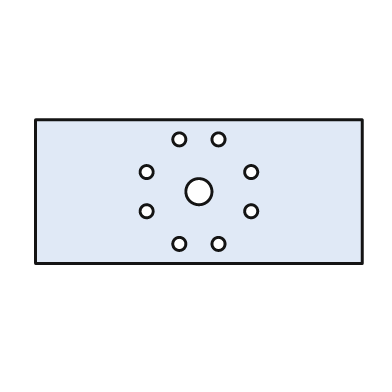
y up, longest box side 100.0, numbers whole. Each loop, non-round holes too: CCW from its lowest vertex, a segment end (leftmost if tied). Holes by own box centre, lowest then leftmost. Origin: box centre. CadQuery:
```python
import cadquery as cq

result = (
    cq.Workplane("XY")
    .moveTo(-50.0, -22.0)
    .lineTo(50.0, -22.0)
    .lineTo(50.0, 22.0)
    .lineTo(-50.0, 22.0)
    .close()
    .moveTo(-6.0, -16.0)
    .circle(2.0)
    .moveTo(6.0, -16.0)
    .circle(2.0)
    .moveTo(-16.0, -6.0)
    .circle(2.0)
    .moveTo(16.0, -6.0)
    .circle(2.0)
    .moveTo(0.0, 0.0)
    .circle(4.0)
    .moveTo(-16.0, 6.0)
    .circle(2.0)
    .moveTo(16.0, 6.0)
    .circle(2.0)
    .moveTo(-6.0, 16.0)
    .circle(2.0)
    .moveTo(6.0, 16.0)
    .circle(2.0)
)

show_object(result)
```